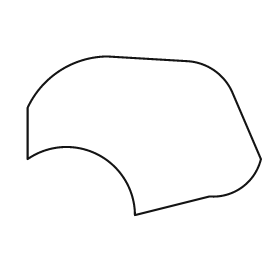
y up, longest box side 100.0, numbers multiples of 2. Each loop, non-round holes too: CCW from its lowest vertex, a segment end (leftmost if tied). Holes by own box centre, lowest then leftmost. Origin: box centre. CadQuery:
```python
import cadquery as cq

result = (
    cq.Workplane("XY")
    .moveTo(-4.0, -34.0)
    .lineTo(28.0, -26.0)
    .threePointArc((42.0, -22.0), (50.0, -10.0))
    .lineTo(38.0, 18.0)
    .threePointArc((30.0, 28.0), (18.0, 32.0))
    .lineTo(-16.0, 34.0)
    .threePointArc((-36.0, 28.0), (-50.0, 12.0))
    .lineTo(-50.0, -10.0)
    .threePointArc((-20.0, -8.0), (-4.0, -34.0))
    .close()
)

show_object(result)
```